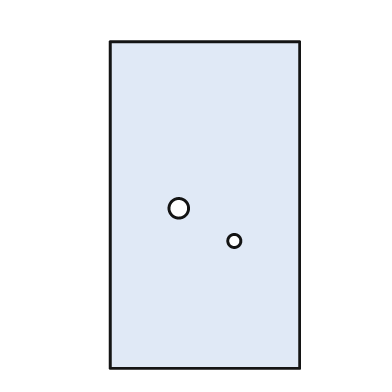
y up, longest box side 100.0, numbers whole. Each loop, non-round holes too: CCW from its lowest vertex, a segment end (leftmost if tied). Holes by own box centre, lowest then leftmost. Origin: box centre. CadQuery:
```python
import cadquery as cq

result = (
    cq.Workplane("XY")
    .moveTo(-29.0, -50.0)
    .lineTo(29.0, -50.0)
    .lineTo(29.0, 50.0)
    .lineTo(-29.0, 50.0)
    .close()
    .moveTo(9.0, -11.0)
    .circle(2.0)
    .moveTo(-8.0, -1.0)
    .circle(3.0)
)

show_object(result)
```